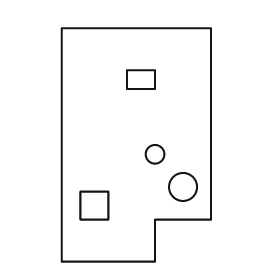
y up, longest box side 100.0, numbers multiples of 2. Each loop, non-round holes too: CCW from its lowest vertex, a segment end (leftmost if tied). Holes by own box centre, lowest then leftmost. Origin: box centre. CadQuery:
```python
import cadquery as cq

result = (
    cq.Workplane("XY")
    .moveTo(-32.0, -50.0)
    .lineTo(8.0, -50.0)
    .lineTo(8.0, -32.0)
    .lineTo(32.0, -32.0)
    .lineTo(32.0, 50.0)
    .lineTo(-32.0, 50.0)
    .close()
    .moveTo(-24.0, -32.0)
    .lineTo(-12.0, -32.0)
    .lineTo(-12.0, -20.0)
    .lineTo(-24.0, -20.0)
    .close()
    .moveTo(20.0, -18.0)
    .circle(6.0)
    .moveTo(8.0, -4.0)
    .circle(4.0)
    .moveTo(-4.0, 24.0)
    .lineTo(8.0, 24.0)
    .lineTo(8.0, 32.0)
    .lineTo(-4.0, 32.0)
    .close()
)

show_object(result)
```